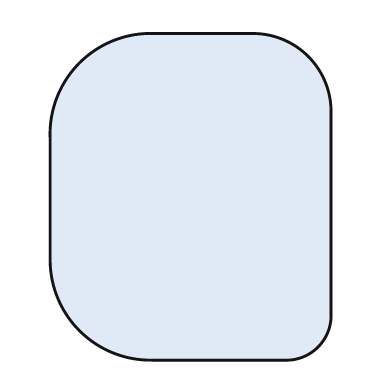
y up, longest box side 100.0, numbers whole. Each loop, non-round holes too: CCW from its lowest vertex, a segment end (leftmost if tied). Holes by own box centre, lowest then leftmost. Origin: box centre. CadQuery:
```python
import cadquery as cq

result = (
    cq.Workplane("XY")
    .moveTo(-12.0, -50.0)
    .lineTo(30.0, -50.0)
    .threePointArc((39.0, -46.0), (43.0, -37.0))
    .lineTo(43.0, 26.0)
    .threePointArc((36.0, 43.0), (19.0, 50.0))
    .lineTo(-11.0, 50.0)
    .threePointArc((-34.0, 41.0), (-43.0, 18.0))
    .lineTo(-43.0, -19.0)
    .threePointArc((-34.0, -41.0), (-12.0, -50.0))
    .close()
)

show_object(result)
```